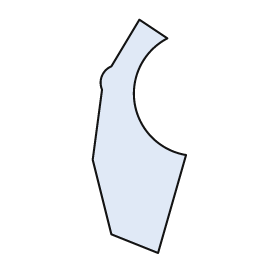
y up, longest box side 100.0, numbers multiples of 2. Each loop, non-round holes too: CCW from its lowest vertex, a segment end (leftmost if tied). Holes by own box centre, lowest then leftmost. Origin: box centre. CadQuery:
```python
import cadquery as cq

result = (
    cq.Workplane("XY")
    .moveTo(8.0, -50.0)
    .lineTo(20.0, -8.0)
    .threePointArc((-2.0, 14.0), (12.0, 42.0))
    .lineTo(0.0, 50.0)
    .lineTo(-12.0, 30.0)
    .threePointArc((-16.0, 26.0), (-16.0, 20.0))
    .lineTo(-20.0, -10.0)
    .lineTo(-12.0, -42.0)
    .close()
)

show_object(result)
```